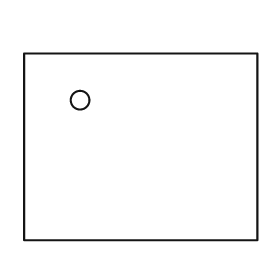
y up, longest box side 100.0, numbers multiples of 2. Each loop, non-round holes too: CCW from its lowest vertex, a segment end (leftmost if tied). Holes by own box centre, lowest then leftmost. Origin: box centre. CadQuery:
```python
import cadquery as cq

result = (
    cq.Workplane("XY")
    .moveTo(-50.0, -40.0)
    .lineTo(50.0, -40.0)
    .lineTo(50.0, 40.0)
    .lineTo(-50.0, 40.0)
    .close()
    .moveTo(-26.0, 20.0)
    .circle(4.0)
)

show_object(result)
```